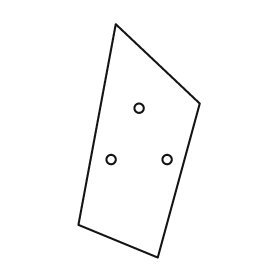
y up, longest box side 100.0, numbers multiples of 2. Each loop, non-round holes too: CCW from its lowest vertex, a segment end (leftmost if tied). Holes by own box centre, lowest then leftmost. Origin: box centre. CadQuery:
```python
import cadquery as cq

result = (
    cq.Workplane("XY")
    .moveTo(8.0, -50.0)
    .lineTo(26.0, 16.0)
    .lineTo(-10.0, 50.0)
    .lineTo(-26.0, -36.0)
    .close()
    .moveTo(-12.0, -8.0)
    .circle(2.0)
    .moveTo(12.0, -8.0)
    .circle(2.0)
    .moveTo(0.0, 14.0)
    .circle(2.0)
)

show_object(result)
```